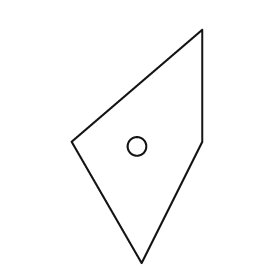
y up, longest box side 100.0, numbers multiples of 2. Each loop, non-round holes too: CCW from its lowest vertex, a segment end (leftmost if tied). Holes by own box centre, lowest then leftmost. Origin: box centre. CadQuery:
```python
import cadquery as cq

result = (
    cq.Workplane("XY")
    .moveTo(2.0, -50.0)
    .lineTo(28.0, 2.0)
    .lineTo(28.0, 50.0)
    .lineTo(-28.0, 2.0)
    .close()
    .moveTo(0.0, 0.0)
    .circle(4.0)
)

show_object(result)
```